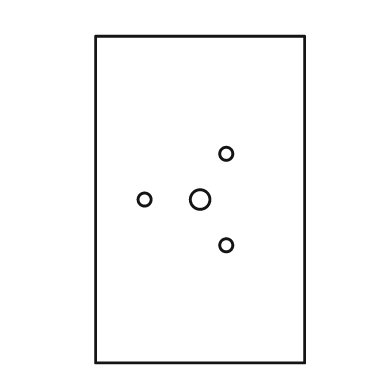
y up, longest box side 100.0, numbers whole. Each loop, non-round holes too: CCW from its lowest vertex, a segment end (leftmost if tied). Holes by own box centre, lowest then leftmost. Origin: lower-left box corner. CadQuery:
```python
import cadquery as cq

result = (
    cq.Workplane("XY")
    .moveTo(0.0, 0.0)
    .lineTo(64.0, 0.0)
    .lineTo(64.0, 100.0)
    .lineTo(0.0, 100.0)
    .close()
    .moveTo(40.0, 36.0)
    .circle(2.0)
    .moveTo(15.0, 50.0)
    .circle(2.0)
    .moveTo(32.0, 50.0)
    .circle(3.0)
    .moveTo(40.0, 64.0)
    .circle(2.0)
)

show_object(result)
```